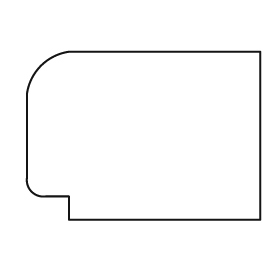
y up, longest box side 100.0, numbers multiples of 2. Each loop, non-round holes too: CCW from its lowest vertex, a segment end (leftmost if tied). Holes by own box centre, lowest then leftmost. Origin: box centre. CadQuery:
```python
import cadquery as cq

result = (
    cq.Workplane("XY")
    .moveTo(-32.0, -36.0)
    .lineTo(50.0, -36.0)
    .lineTo(50.0, 36.0)
    .lineTo(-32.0, 36.0)
    .threePointArc((-44.0, 30.0), (-50.0, 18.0))
    .lineTo(-50.0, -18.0)
    .threePointArc((-48.0, -24.0), (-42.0, -26.0))
    .lineTo(-32.0, -26.0)
    .close()
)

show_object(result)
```